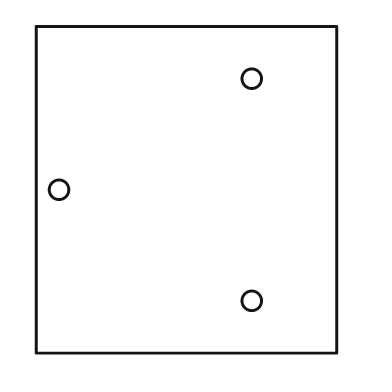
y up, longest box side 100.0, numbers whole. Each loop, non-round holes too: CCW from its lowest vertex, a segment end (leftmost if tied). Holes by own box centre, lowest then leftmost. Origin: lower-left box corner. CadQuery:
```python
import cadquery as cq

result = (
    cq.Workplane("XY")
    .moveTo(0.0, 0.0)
    .lineTo(92.0, 0.0)
    .lineTo(92.0, 100.0)
    .lineTo(0.0, 100.0)
    .close()
    .moveTo(66.0, 16.0)
    .circle(3.0)
    .moveTo(7.0, 50.0)
    .circle(3.0)
    .moveTo(66.0, 84.0)
    .circle(3.0)
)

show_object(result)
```